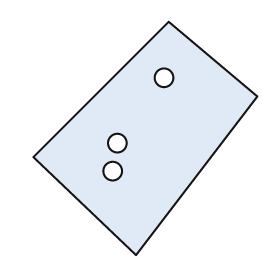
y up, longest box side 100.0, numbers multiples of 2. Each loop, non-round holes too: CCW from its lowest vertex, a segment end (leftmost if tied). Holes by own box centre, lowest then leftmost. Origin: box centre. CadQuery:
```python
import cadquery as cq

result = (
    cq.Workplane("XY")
    .moveTo(-4.0, -50.0)
    .lineTo(48.0, 18.0)
    .lineTo(10.0, 50.0)
    .lineTo(-48.0, -8.0)
    .close()
    .moveTo(-14.0, -14.0)
    .circle(4.0)
    .moveTo(-12.0, -2.0)
    .circle(4.0)
    .moveTo(8.0, 26.0)
    .circle(4.0)
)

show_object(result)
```